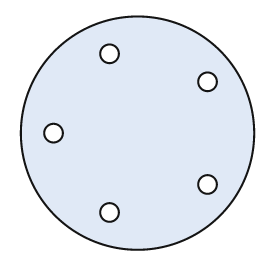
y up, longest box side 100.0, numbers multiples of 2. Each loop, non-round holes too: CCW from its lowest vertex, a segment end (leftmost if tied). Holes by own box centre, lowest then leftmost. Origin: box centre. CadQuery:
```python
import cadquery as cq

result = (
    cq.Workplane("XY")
    .moveTo(0.0, 0.0)
    .circle(50.0)
    .moveTo(-12.0, -34.0)
    .circle(4.0)
    .moveTo(30.0, -22.0)
    .circle(4.0)
    .moveTo(-36.0, 0.0)
    .circle(4.0)
    .moveTo(30.0, 22.0)
    .circle(4.0)
    .moveTo(-12.0, 34.0)
    .circle(4.0)
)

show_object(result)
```